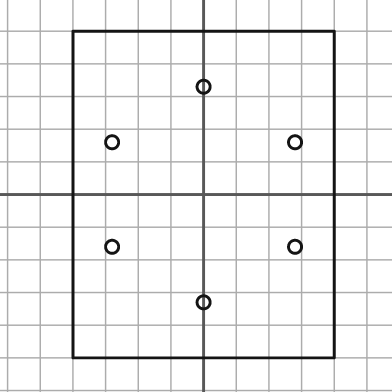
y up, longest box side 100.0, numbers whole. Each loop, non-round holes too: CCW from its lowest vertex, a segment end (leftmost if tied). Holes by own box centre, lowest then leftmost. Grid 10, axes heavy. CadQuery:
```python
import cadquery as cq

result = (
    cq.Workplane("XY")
    .moveTo(-40.0, -50.0)
    .lineTo(40.0, -50.0)
    .lineTo(40.0, 50.0)
    .lineTo(-40.0, 50.0)
    .close()
    .moveTo(0.0, -33.0)
    .circle(2.0)
    .moveTo(-28.0, -16.0)
    .circle(2.0)
    .moveTo(28.0, -16.0)
    .circle(2.0)
    .moveTo(-28.0, 16.0)
    .circle(2.0)
    .moveTo(28.0, 16.0)
    .circle(2.0)
    .moveTo(0.0, 33.0)
    .circle(2.0)
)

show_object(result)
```